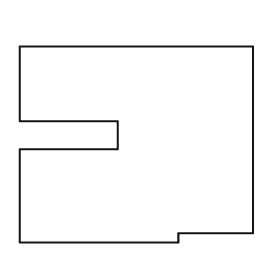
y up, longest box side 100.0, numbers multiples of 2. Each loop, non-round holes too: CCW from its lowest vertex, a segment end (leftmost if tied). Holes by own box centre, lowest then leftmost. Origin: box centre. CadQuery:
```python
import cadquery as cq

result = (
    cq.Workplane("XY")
    .moveTo(-50.0, -42.0)
    .lineTo(18.0, -42.0)
    .lineTo(18.0, -38.0)
    .lineTo(50.0, -38.0)
    .lineTo(50.0, 42.0)
    .lineTo(-50.0, 42.0)
    .lineTo(-50.0, 10.0)
    .lineTo(-8.0, 10.0)
    .lineTo(-8.0, -2.0)
    .lineTo(-50.0, -2.0)
    .close()
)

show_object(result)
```